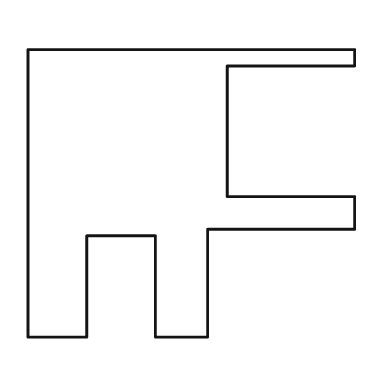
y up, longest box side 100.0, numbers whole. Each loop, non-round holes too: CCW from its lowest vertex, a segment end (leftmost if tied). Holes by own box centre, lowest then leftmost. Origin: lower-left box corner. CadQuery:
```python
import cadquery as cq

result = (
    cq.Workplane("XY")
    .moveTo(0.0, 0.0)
    .lineTo(18.0, 0.0)
    .lineTo(18.0, 31.0)
    .lineTo(39.0, 31.0)
    .lineTo(39.0, 0.0)
    .lineTo(55.0, 0.0)
    .lineTo(55.0, 33.0)
    .lineTo(100.0, 33.0)
    .lineTo(100.0, 43.0)
    .lineTo(61.0, 43.0)
    .lineTo(61.0, 83.0)
    .lineTo(100.0, 83.0)
    .lineTo(100.0, 88.0)
    .lineTo(0.0, 88.0)
    .close()
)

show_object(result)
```